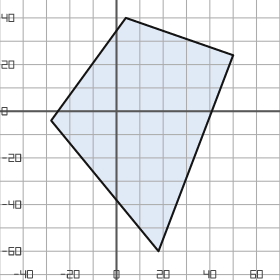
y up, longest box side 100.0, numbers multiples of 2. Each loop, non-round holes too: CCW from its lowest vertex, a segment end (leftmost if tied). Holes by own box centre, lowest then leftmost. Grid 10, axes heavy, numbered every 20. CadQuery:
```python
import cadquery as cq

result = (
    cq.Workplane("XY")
    .moveTo(18.0, -60.0)
    .lineTo(50.0, 24.0)
    .lineTo(4.0, 40.0)
    .lineTo(-28.0, -4.0)
    .close()
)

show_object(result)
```